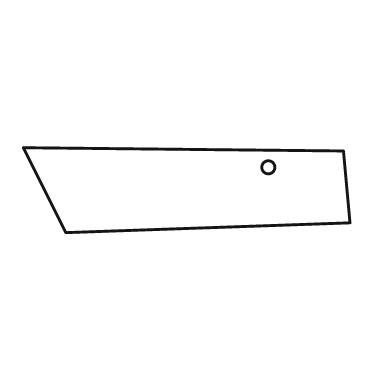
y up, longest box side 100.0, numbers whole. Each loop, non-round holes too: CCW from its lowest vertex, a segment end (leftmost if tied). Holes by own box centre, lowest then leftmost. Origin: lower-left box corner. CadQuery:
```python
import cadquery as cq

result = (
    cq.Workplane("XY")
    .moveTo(13.0, 0.0)
    .lineTo(100.0, 3.0)
    .lineTo(98.0, 25.0)
    .lineTo(0.0, 26.0)
    .close()
    .moveTo(75.0, 20.0)
    .circle(2.0)
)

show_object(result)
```